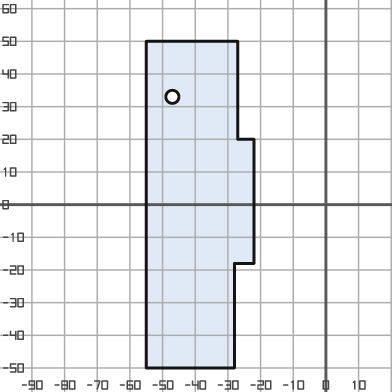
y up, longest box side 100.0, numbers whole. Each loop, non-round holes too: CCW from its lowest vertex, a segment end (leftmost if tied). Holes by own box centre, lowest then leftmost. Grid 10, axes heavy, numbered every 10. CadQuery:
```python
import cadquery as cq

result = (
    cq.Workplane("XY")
    .moveTo(-55.0, -50.0)
    .lineTo(-28.0, -50.0)
    .lineTo(-28.0, -18.0)
    .lineTo(-22.0, -18.0)
    .lineTo(-22.0, 20.0)
    .lineTo(-27.0, 20.0)
    .lineTo(-27.0, 50.0)
    .lineTo(-55.0, 50.0)
    .close()
    .moveTo(-47.0, 33.0)
    .circle(2.0)
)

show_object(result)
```